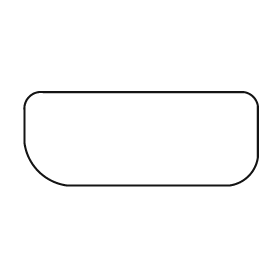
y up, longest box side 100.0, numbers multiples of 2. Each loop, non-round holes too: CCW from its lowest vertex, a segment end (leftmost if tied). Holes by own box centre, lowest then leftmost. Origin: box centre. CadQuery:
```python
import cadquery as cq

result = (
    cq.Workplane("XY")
    .moveTo(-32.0, -20.0)
    .lineTo(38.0, -20.0)
    .threePointArc((46.0, -16.0), (50.0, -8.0))
    .lineTo(50.0, 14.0)
    .threePointArc((48.0, 18.0), (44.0, 20.0))
    .lineTo(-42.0, 20.0)
    .threePointArc((-48.0, 18.0), (-50.0, 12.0))
    .lineTo(-50.0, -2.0)
    .threePointArc((-44.0, -14.0), (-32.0, -20.0))
    .close()
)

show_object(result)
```